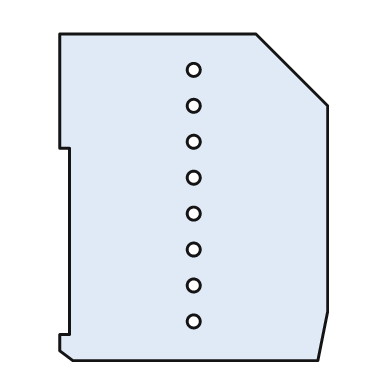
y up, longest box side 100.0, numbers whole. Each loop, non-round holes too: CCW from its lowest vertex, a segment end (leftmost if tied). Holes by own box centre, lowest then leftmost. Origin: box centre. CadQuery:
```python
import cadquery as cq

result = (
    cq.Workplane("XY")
    .moveTo(-37.0, -50.0)
    .lineTo(38.0, -50.0)
    .lineTo(41.0, -35.0)
    .lineTo(41.0, 28.0)
    .lineTo(19.0, 50.0)
    .lineTo(-41.0, 50.0)
    .lineTo(-41.0, 15.0)
    .lineTo(-38.0, 15.0)
    .lineTo(-38.0, -42.0)
    .lineTo(-41.0, -42.0)
    .lineTo(-41.0, -47.0)
    .close()
    .moveTo(0.0, -38.0)
    .circle(2.0)
    .moveTo(0.0, -27.0)
    .circle(2.0)
    .moveTo(0.0, -16.0)
    .circle(2.0)
    .moveTo(0.0, -5.0)
    .circle(2.0)
    .moveTo(0.0, 6.0)
    .circle(2.0)
    .moveTo(0.0, 17.0)
    .circle(2.0)
    .moveTo(0.0, 28.0)
    .circle(2.0)
    .moveTo(0.0, 39.0)
    .circle(2.0)
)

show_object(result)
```